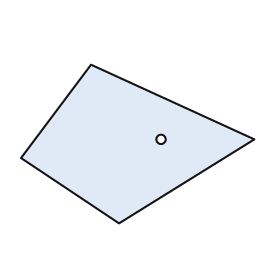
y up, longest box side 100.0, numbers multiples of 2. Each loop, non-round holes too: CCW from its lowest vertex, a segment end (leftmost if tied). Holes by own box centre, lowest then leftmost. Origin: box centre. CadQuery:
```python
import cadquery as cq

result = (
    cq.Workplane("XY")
    .moveTo(-8.0, -34.0)
    .lineTo(50.0, 2.0)
    .lineTo(-20.0, 34.0)
    .lineTo(-50.0, -6.0)
    .close()
    .moveTo(10.0, 2.0)
    .circle(2.0)
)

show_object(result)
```